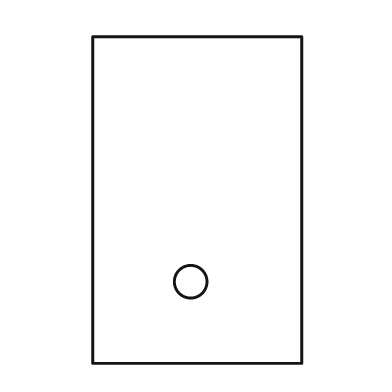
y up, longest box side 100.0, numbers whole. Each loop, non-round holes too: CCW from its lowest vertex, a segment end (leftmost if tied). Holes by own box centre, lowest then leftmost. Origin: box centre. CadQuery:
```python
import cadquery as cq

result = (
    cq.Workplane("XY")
    .moveTo(-32.0, -50.0)
    .lineTo(32.0, -50.0)
    .lineTo(32.0, 50.0)
    .lineTo(-32.0, 50.0)
    .close()
    .moveTo(-2.0, -25.0)
    .circle(5.0)
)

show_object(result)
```